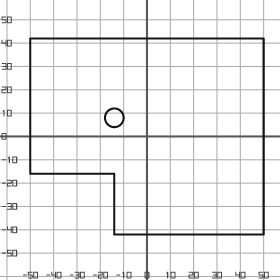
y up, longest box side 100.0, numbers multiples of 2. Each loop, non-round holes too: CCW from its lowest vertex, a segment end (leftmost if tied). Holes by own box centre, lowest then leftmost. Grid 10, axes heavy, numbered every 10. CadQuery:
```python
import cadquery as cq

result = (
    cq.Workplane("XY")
    .moveTo(-14.0, -42.0)
    .lineTo(50.0, -42.0)
    .lineTo(50.0, 42.0)
    .lineTo(-50.0, 42.0)
    .lineTo(-50.0, -16.0)
    .lineTo(-14.0, -16.0)
    .close()
    .moveTo(-14.0, 8.0)
    .circle(4.0)
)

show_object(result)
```